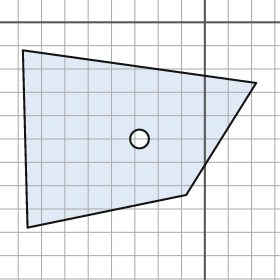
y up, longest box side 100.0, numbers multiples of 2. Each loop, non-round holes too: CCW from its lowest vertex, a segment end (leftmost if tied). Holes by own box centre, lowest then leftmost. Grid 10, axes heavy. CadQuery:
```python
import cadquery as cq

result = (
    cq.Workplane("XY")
    .moveTo(-76.0, -88.0)
    .lineTo(-8.0, -74.0)
    .lineTo(22.0, -26.0)
    .lineTo(-78.0, -12.0)
    .close()
    .moveTo(-28.0, -50.0)
    .circle(4.0)
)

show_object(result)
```